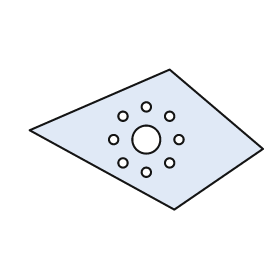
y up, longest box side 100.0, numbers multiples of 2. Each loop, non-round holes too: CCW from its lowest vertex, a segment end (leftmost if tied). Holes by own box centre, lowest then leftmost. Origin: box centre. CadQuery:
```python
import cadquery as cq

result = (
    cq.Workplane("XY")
    .moveTo(12.0, -30.0)
    .lineTo(50.0, -4.0)
    .lineTo(10.0, 30.0)
    .lineTo(-50.0, 4.0)
    .close()
    .moveTo(0.0, -14.0)
    .circle(2.0)
    .moveTo(-10.0, -10.0)
    .circle(2.0)
    .moveTo(10.0, -10.0)
    .circle(2.0)
    .moveTo(-14.0, 0.0)
    .circle(2.0)
    .moveTo(0.0, 0.0)
    .circle(6.0)
    .moveTo(14.0, 0.0)
    .circle(2.0)
    .moveTo(-10.0, 10.0)
    .circle(2.0)
    .moveTo(10.0, 10.0)
    .circle(2.0)
    .moveTo(0.0, 14.0)
    .circle(2.0)
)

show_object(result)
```